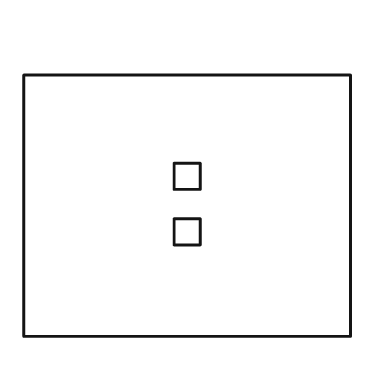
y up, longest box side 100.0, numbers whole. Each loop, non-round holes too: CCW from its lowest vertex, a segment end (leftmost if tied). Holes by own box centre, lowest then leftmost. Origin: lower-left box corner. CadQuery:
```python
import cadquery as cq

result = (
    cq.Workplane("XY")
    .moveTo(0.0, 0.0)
    .lineTo(100.0, 0.0)
    .lineTo(100.0, 80.0)
    .lineTo(0.0, 80.0)
    .close()
    .moveTo(46.0, 28.0)
    .lineTo(54.0, 28.0)
    .lineTo(54.0, 36.0)
    .lineTo(46.0, 36.0)
    .close()
    .moveTo(46.0, 45.0)
    .lineTo(54.0, 45.0)
    .lineTo(54.0, 53.0)
    .lineTo(46.0, 53.0)
    .close()
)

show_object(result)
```